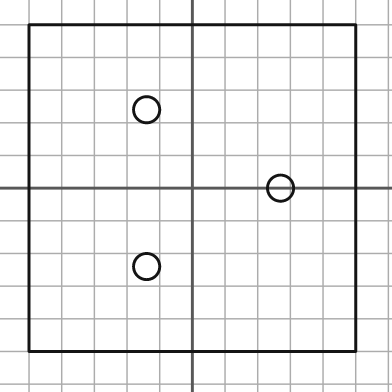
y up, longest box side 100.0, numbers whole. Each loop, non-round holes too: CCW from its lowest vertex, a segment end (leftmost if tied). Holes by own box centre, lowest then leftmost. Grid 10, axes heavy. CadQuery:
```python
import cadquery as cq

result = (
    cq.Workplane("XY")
    .moveTo(-50.0, -50.0)
    .lineTo(50.0, -50.0)
    .lineTo(50.0, 50.0)
    .lineTo(-50.0, 50.0)
    .close()
    .moveTo(-14.0, -24.0)
    .circle(4.0)
    .moveTo(27.0, 0.0)
    .circle(4.0)
    .moveTo(-14.0, 24.0)
    .circle(4.0)
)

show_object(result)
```